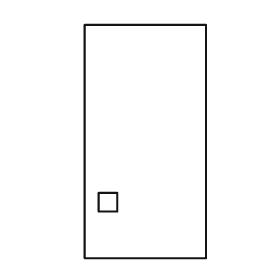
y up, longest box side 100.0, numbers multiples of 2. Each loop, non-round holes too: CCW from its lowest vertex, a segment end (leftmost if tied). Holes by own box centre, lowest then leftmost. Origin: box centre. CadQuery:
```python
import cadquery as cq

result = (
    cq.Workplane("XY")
    .moveTo(-26.0, -50.0)
    .lineTo(26.0, -50.0)
    .lineTo(26.0, 50.0)
    .lineTo(-26.0, 50.0)
    .close()
    .moveTo(-20.0, -30.0)
    .lineTo(-12.0, -30.0)
    .lineTo(-12.0, -22.0)
    .lineTo(-20.0, -22.0)
    .close()
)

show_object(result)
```